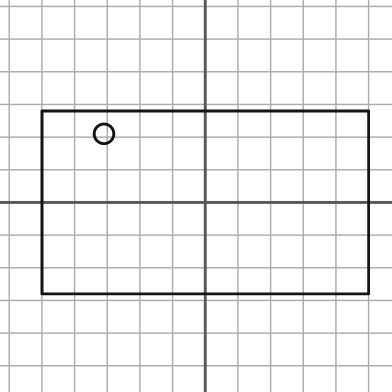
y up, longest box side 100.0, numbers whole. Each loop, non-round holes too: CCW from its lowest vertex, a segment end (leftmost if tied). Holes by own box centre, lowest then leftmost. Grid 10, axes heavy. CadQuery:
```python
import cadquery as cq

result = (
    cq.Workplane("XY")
    .moveTo(-50.0, -28.0)
    .lineTo(50.0, -28.0)
    .lineTo(50.0, 28.0)
    .lineTo(-50.0, 28.0)
    .close()
    .moveTo(-31.0, 21.0)
    .circle(3.0)
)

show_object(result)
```